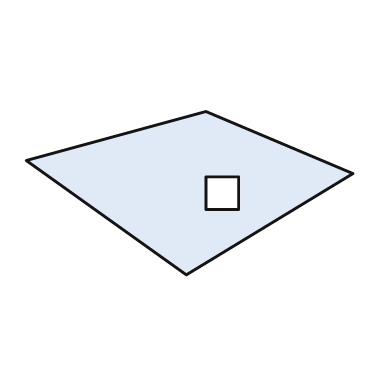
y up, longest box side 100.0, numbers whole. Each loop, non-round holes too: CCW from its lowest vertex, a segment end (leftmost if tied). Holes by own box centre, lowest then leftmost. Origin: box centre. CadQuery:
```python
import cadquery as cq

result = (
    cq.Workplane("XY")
    .moveTo(-1.0, -25.0)
    .lineTo(50.0, 6.0)
    .lineTo(5.0, 25.0)
    .lineTo(-50.0, 10.0)
    .close()
    .moveTo(5.0, -5.0)
    .lineTo(15.0, -5.0)
    .lineTo(15.0, 5.0)
    .lineTo(5.0, 5.0)
    .close()
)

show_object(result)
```